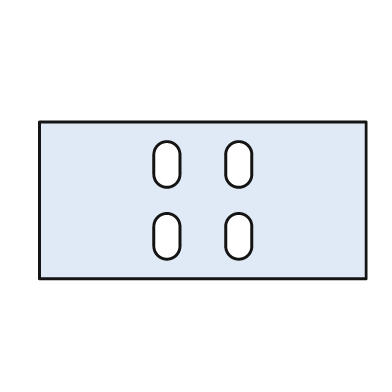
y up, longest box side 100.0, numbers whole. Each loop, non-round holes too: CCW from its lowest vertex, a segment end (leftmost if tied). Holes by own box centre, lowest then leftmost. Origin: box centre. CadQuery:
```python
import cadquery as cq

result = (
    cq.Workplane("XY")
    .moveTo(-50.0, -24.0)
    .lineTo(50.0, -24.0)
    .lineTo(50.0, 24.0)
    .lineTo(-50.0, 24.0)
    .close()
    .moveTo(-15.0, -14.0)
    .threePointArc((-11.0, -18.0), (-7.0, -14.0))
    .lineTo(-7.0, -8.0)
    .threePointArc((-11.0, -4.0), (-15.0, -8.0))
    .close()
    .moveTo(7.0, -14.0)
    .threePointArc((11.0, -18.0), (15.0, -14.0))
    .lineTo(15.0, -8.0)
    .threePointArc((11.0, -4.0), (7.0, -8.0))
    .close()
    .moveTo(-15.0, 8.0)
    .threePointArc((-11.0, 4.0), (-7.0, 8.0))
    .lineTo(-7.0, 14.0)
    .threePointArc((-11.0, 18.0), (-15.0, 14.0))
    .close()
    .moveTo(7.0, 8.0)
    .threePointArc((11.0, 4.0), (15.0, 8.0))
    .lineTo(15.0, 14.0)
    .threePointArc((11.0, 18.0), (7.0, 14.0))
    .close()
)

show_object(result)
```